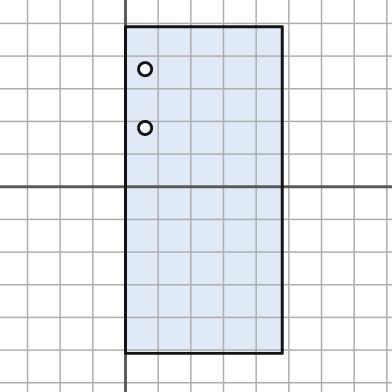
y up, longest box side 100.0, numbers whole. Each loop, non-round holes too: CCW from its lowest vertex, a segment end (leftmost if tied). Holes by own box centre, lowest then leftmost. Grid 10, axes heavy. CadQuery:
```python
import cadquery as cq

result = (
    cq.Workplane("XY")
    .moveTo(0.0, -51.0)
    .lineTo(48.0, -51.0)
    .lineTo(48.0, 49.0)
    .lineTo(0.0, 49.0)
    .close()
    .moveTo(6.0, 18.0)
    .circle(2.0)
    .moveTo(6.0, 36.0)
    .circle(2.0)
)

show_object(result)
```